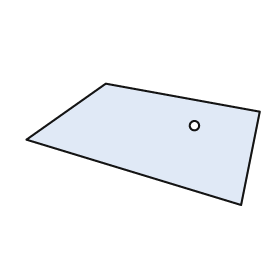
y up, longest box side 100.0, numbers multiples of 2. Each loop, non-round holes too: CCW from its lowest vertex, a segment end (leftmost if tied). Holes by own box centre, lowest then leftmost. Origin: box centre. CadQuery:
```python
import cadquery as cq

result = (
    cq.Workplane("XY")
    .moveTo(42.0, -26.0)
    .lineTo(50.0, 14.0)
    .lineTo(-16.0, 26.0)
    .lineTo(-50.0, 2.0)
    .close()
    .moveTo(22.0, 8.0)
    .circle(2.0)
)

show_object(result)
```